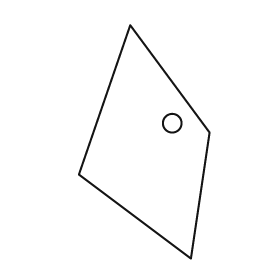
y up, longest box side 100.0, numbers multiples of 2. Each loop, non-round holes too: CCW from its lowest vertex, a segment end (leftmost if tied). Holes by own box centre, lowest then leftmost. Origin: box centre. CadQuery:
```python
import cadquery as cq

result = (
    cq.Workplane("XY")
    .moveTo(20.0, -50.0)
    .lineTo(28.0, 4.0)
    .lineTo(-6.0, 50.0)
    .lineTo(-28.0, -14.0)
    .close()
    .moveTo(12.0, 8.0)
    .circle(4.0)
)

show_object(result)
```